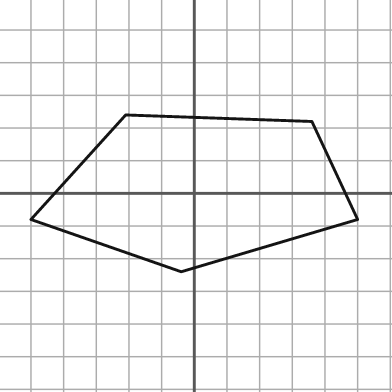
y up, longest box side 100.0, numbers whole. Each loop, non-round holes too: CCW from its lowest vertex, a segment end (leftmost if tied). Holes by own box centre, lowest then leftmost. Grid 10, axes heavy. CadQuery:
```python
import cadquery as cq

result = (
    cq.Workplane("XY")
    .moveTo(-4.0, -24.0)
    .lineTo(50.0, -8.0)
    .lineTo(36.0, 22.0)
    .lineTo(-21.0, 24.0)
    .lineTo(-50.0, -8.0)
    .close()
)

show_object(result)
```